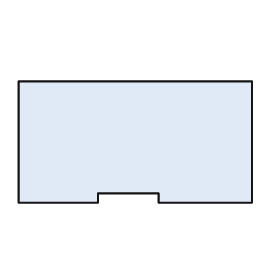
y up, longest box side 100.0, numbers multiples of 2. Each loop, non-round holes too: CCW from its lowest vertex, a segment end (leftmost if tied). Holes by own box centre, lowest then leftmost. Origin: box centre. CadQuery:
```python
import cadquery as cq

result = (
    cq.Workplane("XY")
    .moveTo(-50.0, -26.0)
    .lineTo(-16.0, -26.0)
    .lineTo(-16.0, -22.0)
    .lineTo(10.0, -22.0)
    .lineTo(10.0, -26.0)
    .lineTo(50.0, -26.0)
    .lineTo(50.0, 26.0)
    .lineTo(-50.0, 26.0)
    .close()
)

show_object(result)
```